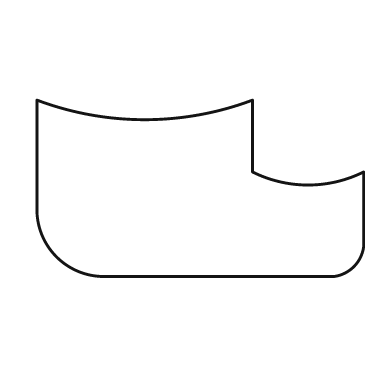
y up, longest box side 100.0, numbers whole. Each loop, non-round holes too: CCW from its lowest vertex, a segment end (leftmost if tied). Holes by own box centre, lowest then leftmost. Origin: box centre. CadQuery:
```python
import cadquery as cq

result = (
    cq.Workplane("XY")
    .moveTo(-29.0, -27.0)
    .lineTo(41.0, -27.0)
    .threePointArc((47.0, -24.0), (50.0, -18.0))
    .lineTo(50.0, 5.0)
    .threePointArc((33.0, 1.0), (16.0, 5.0))
    .lineTo(16.0, 27.0)
    .threePointArc((-17.0, 21.0), (-50.0, 27.0))
    .lineTo(-50.0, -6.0)
    .threePointArc((-44.0, -21.0), (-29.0, -27.0))
    .close()
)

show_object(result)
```